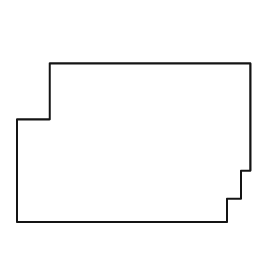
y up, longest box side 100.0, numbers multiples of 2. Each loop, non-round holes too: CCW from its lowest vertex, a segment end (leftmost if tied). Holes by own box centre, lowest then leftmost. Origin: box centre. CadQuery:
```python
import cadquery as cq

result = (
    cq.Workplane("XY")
    .moveTo(-50.0, -34.0)
    .lineTo(40.0, -34.0)
    .lineTo(40.0, -24.0)
    .lineTo(46.0, -24.0)
    .lineTo(46.0, -12.0)
    .lineTo(50.0, -12.0)
    .lineTo(50.0, 34.0)
    .lineTo(-36.0, 34.0)
    .lineTo(-36.0, 10.0)
    .lineTo(-50.0, 10.0)
    .close()
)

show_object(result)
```